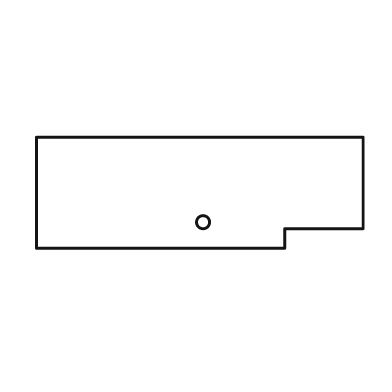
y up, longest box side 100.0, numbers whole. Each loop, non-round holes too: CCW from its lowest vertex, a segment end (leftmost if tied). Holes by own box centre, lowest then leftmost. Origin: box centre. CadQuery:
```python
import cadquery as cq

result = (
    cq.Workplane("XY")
    .moveTo(-50.0, -17.0)
    .lineTo(26.0, -17.0)
    .lineTo(26.0, -11.0)
    .lineTo(50.0, -11.0)
    .lineTo(50.0, 17.0)
    .lineTo(-50.0, 17.0)
    .close()
    .moveTo(1.0, -9.0)
    .circle(2.0)
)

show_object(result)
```